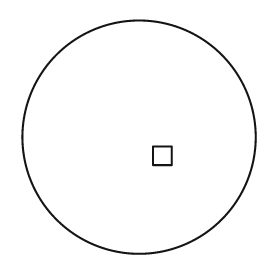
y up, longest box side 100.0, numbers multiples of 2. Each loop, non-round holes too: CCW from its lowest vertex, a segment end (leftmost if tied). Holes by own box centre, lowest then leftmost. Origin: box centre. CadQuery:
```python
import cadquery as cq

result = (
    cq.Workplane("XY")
    .moveTo(0.0, 0.0)
    .circle(50.0)
    .moveTo(6.0, -12.0)
    .lineTo(14.0, -12.0)
    .lineTo(14.0, -4.0)
    .lineTo(6.0, -4.0)
    .close()
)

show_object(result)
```